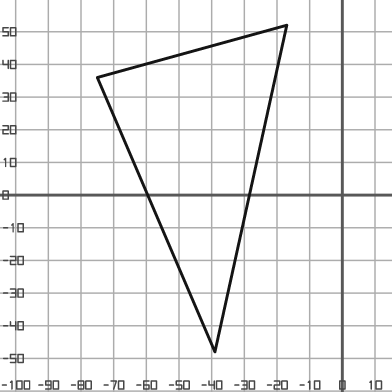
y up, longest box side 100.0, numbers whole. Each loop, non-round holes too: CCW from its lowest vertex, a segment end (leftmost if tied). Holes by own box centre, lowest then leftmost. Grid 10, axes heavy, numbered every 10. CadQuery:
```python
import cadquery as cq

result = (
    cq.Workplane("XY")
    .moveTo(-39.0, -48.0)
    .lineTo(-17.0, 52.0)
    .lineTo(-75.0, 36.0)
    .close()
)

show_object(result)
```